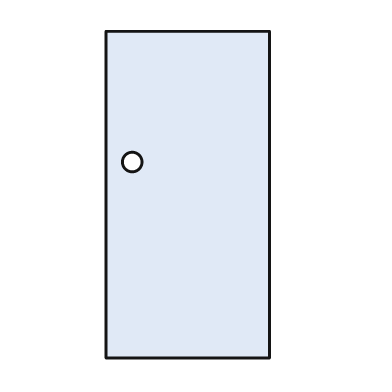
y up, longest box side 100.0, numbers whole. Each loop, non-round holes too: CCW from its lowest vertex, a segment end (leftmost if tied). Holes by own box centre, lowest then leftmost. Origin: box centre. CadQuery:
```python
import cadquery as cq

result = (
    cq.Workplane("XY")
    .moveTo(-25.0, -50.0)
    .lineTo(25.0, -50.0)
    .lineTo(25.0, 50.0)
    .lineTo(-25.0, 50.0)
    .close()
    .moveTo(-17.0, 10.0)
    .circle(3.0)
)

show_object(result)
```